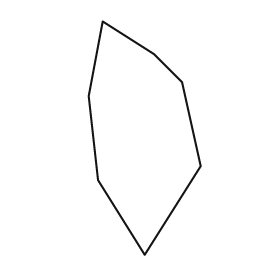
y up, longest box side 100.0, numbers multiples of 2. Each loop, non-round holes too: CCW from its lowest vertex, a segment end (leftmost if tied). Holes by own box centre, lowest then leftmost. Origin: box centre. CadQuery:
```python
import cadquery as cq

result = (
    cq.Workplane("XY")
    .moveTo(0.0, -50.0)
    .lineTo(24.0, -12.0)
    .lineTo(16.0, 24.0)
    .lineTo(4.0, 36.0)
    .lineTo(-18.0, 50.0)
    .lineTo(-24.0, 18.0)
    .lineTo(-20.0, -18.0)
    .close()
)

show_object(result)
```